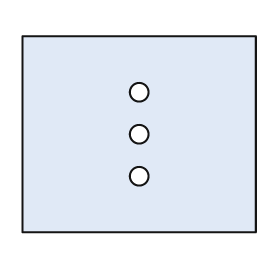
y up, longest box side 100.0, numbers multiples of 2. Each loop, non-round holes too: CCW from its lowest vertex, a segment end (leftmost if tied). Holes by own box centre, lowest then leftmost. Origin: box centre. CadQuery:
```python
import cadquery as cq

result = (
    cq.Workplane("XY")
    .moveTo(-50.0, -42.0)
    .lineTo(50.0, -42.0)
    .lineTo(50.0, 42.0)
    .lineTo(-50.0, 42.0)
    .close()
    .moveTo(0.0, -18.0)
    .circle(4.0)
    .moveTo(0.0, 0.0)
    .circle(4.0)
    .moveTo(0.0, 18.0)
    .circle(4.0)
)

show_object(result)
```